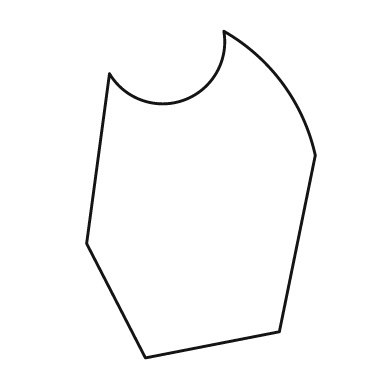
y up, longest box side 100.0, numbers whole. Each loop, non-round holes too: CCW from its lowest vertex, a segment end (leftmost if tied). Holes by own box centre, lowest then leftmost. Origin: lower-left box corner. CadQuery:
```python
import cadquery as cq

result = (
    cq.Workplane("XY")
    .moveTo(18.0, 0.0)
    .lineTo(59.0, 8.0)
    .lineTo(70.0, 62.0)
    .threePointArc((60.0, 84.0), (42.0, 100.0))
    .threePointArc((30.0, 79.0), (7.0, 87.0))
    .lineTo(0.0, 35.0)
    .close()
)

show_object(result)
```